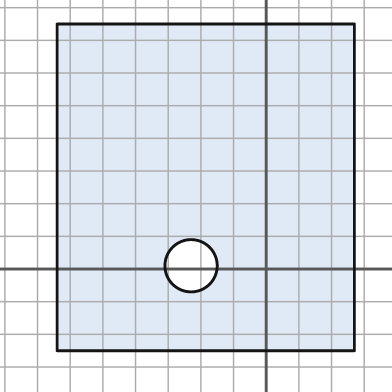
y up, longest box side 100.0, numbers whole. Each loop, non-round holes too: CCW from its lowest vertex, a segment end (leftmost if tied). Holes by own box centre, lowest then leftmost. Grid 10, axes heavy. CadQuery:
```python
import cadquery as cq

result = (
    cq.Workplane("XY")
    .moveTo(-64.0, -25.0)
    .lineTo(27.0, -25.0)
    .lineTo(27.0, 75.0)
    .lineTo(-64.0, 75.0)
    .close()
    .moveTo(-23.0, 1.0)
    .circle(8.0)
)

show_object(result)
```